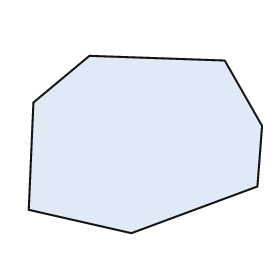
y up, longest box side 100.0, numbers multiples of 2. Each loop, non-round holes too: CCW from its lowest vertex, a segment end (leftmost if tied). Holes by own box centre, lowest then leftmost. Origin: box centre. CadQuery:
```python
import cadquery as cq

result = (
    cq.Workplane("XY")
    .moveTo(-6.0, -38.0)
    .lineTo(48.0, -18.0)
    .lineTo(50.0, 8.0)
    .lineTo(34.0, 36.0)
    .lineTo(-24.0, 38.0)
    .lineTo(-48.0, 18.0)
    .lineTo(-50.0, -28.0)
    .close()
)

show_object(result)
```